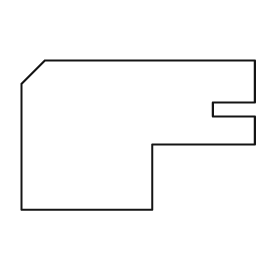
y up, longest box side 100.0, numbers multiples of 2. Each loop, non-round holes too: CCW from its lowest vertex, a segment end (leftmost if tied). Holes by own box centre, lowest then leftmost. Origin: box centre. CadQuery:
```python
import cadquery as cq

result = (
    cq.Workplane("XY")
    .moveTo(-50.0, -32.0)
    .lineTo(6.0, -32.0)
    .lineTo(6.0, -4.0)
    .lineTo(50.0, -4.0)
    .lineTo(50.0, 8.0)
    .lineTo(32.0, 8.0)
    .lineTo(32.0, 14.0)
    .lineTo(50.0, 14.0)
    .lineTo(50.0, 32.0)
    .lineTo(-40.0, 32.0)
    .lineTo(-50.0, 22.0)
    .close()
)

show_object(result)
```